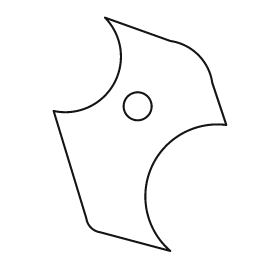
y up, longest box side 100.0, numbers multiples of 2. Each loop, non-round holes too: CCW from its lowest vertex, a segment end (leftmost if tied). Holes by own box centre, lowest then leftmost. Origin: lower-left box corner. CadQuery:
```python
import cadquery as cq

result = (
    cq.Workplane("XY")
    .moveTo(50.0, 0.0)
    .threePointArc((42.0, 36.0), (74.0, 54.0))
    .lineTo(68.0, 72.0)
    .threePointArc((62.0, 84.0), (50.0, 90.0))
    .lineTo(22.0, 100.0)
    .threePointArc((26.0, 72.0), (0.0, 60.0))
    .lineTo(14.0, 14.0)
    .threePointArc((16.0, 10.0), (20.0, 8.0))
    .close()
    .moveTo(36.0, 62.0)
    .circle(6.0)
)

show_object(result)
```